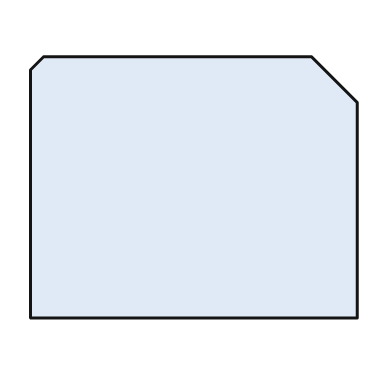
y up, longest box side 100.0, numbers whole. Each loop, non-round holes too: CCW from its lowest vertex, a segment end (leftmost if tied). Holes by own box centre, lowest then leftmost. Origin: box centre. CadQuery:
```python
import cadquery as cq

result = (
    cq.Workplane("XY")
    .moveTo(-50.0, -40.0)
    .lineTo(50.0, -40.0)
    .lineTo(50.0, 26.0)
    .lineTo(36.0, 40.0)
    .lineTo(-46.0, 40.0)
    .lineTo(-50.0, 36.0)
    .close()
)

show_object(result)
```